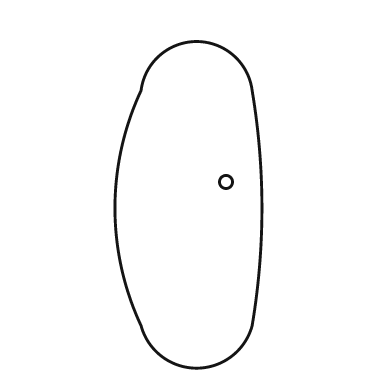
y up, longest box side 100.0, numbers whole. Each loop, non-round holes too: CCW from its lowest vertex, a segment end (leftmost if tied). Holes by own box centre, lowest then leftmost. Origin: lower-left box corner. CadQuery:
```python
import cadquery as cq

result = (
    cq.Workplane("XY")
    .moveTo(8.0, 13.0)
    .threePointArc((25.0, 0.0), (42.0, 13.0))
    .threePointArc((45.0, 49.0), (42.0, 85.0))
    .threePointArc((25.0, 100.0), (8.0, 85.0))
    .threePointArc((0.0, 49.0), (8.0, 13.0))
    .close()
    .moveTo(34.0, 57.0)
    .circle(2.0)
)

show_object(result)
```